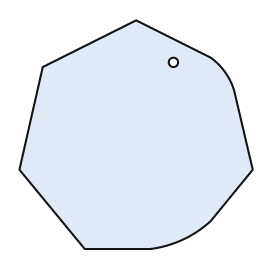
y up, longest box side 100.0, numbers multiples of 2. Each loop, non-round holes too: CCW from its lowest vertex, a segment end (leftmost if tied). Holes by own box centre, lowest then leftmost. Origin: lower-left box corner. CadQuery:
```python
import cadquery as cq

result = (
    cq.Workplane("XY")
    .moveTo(28.0, 0.0)
    .lineTo(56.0, 0.0)
    .threePointArc((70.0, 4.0), (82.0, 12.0))
    .lineTo(100.0, 34.0)
    .lineTo(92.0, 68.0)
    .threePointArc((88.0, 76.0), (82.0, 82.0))
    .lineTo(50.0, 98.0)
    .lineTo(10.0, 78.0)
    .lineTo(0.0, 34.0)
    .close()
    .moveTo(66.0, 80.0)
    .circle(2.0)
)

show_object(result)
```